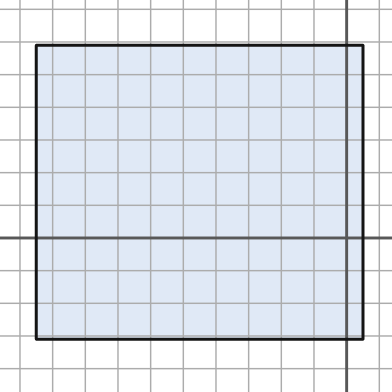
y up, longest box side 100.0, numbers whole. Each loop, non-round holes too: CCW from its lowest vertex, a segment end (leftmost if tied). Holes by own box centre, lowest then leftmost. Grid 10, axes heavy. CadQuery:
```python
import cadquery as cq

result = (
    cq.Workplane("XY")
    .moveTo(-95.0, -31.0)
    .lineTo(5.0, -31.0)
    .lineTo(5.0, 59.0)
    .lineTo(-95.0, 59.0)
    .close()
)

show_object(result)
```